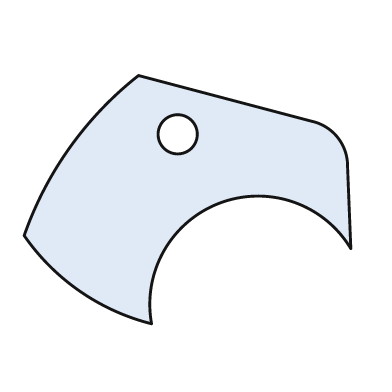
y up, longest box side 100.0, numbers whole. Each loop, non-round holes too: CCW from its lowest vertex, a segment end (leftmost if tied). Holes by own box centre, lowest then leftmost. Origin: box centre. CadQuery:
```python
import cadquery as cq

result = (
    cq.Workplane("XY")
    .moveTo(-11.0, -38.0)
    .threePointArc((10.0, -1.0), (50.0, -15.0))
    .lineTo(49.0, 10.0)
    .threePointArc((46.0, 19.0), (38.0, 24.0))
    .lineTo(-15.0, 38.0)
    .threePointArc((-36.0, 16.0), (-50.0, -11.0))
    .threePointArc((-33.0, -28.0), (-11.0, -38.0))
    .close()
    .moveTo(-3.0, 20.0)
    .circle(6.0)
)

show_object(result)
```